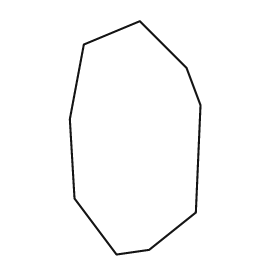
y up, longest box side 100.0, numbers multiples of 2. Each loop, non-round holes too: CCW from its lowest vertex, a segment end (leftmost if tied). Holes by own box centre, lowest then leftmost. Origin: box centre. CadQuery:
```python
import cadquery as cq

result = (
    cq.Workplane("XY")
    .moveTo(-8.0, -50.0)
    .lineTo(6.0, -48.0)
    .lineTo(26.0, -32.0)
    .lineTo(28.0, 14.0)
    .lineTo(22.0, 30.0)
    .lineTo(2.0, 50.0)
    .lineTo(-22.0, 40.0)
    .lineTo(-28.0, 8.0)
    .lineTo(-26.0, -26.0)
    .close()
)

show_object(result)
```